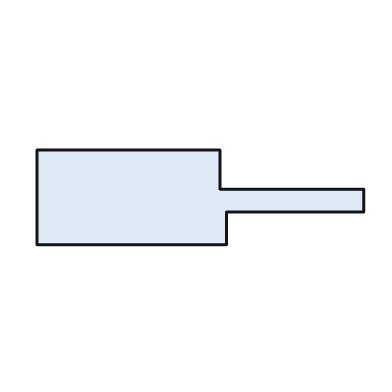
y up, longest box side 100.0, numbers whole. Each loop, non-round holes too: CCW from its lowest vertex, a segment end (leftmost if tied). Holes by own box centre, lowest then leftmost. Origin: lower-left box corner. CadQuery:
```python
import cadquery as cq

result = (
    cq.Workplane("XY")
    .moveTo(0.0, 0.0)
    .lineTo(58.0, 0.0)
    .lineTo(58.0, 10.0)
    .lineTo(100.0, 10.0)
    .lineTo(100.0, 17.0)
    .lineTo(56.0, 17.0)
    .lineTo(56.0, 29.0)
    .lineTo(0.0, 29.0)
    .close()
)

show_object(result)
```